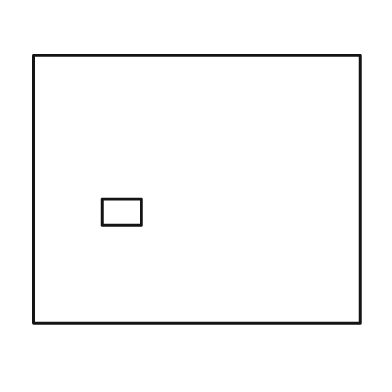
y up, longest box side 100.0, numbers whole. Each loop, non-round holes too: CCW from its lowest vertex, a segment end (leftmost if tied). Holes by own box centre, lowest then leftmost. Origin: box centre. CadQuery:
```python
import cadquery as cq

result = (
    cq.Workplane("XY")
    .moveTo(-50.0, -41.0)
    .lineTo(50.0, -41.0)
    .lineTo(50.0, 41.0)
    .lineTo(-50.0, 41.0)
    .close()
    .moveTo(-29.0, -11.0)
    .lineTo(-17.0, -11.0)
    .lineTo(-17.0, -3.0)
    .lineTo(-29.0, -3.0)
    .close()
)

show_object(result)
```